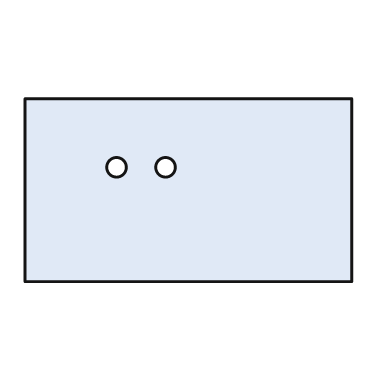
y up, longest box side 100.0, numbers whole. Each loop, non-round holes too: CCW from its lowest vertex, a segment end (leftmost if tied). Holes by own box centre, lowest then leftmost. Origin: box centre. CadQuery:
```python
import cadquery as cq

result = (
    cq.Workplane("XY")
    .moveTo(-50.0, -28.0)
    .lineTo(50.0, -28.0)
    .lineTo(50.0, 28.0)
    .lineTo(-50.0, 28.0)
    .close()
    .moveTo(-22.0, 7.0)
    .circle(3.0)
    .moveTo(-7.0, 7.0)
    .circle(3.0)
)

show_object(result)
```